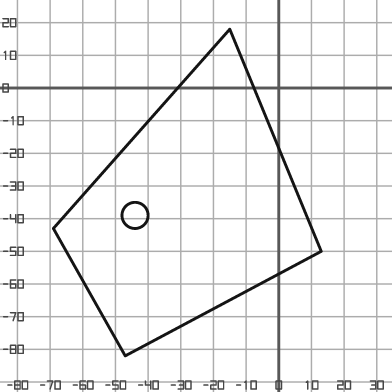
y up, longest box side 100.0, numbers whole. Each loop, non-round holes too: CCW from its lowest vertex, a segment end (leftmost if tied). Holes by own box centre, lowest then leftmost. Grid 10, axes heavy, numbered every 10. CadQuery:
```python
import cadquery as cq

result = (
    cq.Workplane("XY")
    .moveTo(-47.0, -82.0)
    .lineTo(13.0, -50.0)
    .lineTo(-15.0, 18.0)
    .lineTo(-69.0, -43.0)
    .close()
    .moveTo(-44.0, -39.0)
    .circle(4.0)
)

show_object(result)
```